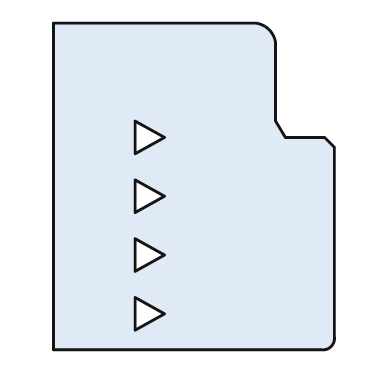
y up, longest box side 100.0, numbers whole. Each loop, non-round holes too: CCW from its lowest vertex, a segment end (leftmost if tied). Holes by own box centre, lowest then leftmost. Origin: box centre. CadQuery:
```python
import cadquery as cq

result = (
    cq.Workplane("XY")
    .moveTo(-43.0, -50.0)
    .lineTo(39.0, -50.0)
    .threePointArc((42.0, -49.0), (43.0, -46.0))
    .lineTo(43.0, 12.0)
    .lineTo(40.0, 15.0)
    .lineTo(28.0, 15.0)
    .lineTo(25.0, 20.0)
    .lineTo(25.0, 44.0)
    .threePointArc((23.0, 48.0), (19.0, 50.0))
    .lineTo(-43.0, 50.0)
    .close()
    .moveTo(-18.0, -44.0)
    .lineTo(-9.0, -39.0)
    .lineTo(-18.0, -34.0)
    .close()
    .moveTo(-18.0, -26.0)
    .lineTo(-9.0, -21.0)
    .lineTo(-18.0, -16.0)
    .close()
    .moveTo(-18.0, -8.0)
    .lineTo(-9.0, -3.0)
    .lineTo(-18.0, 2.0)
    .close()
    .moveTo(-18.0, 10.0)
    .lineTo(-9.0, 15.0)
    .lineTo(-18.0, 20.0)
    .close()
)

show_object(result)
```